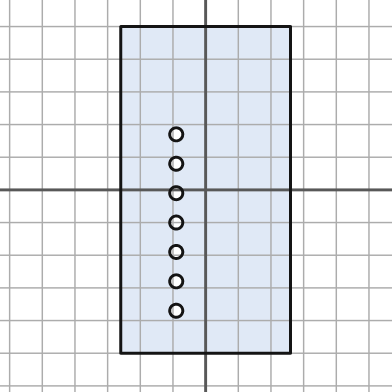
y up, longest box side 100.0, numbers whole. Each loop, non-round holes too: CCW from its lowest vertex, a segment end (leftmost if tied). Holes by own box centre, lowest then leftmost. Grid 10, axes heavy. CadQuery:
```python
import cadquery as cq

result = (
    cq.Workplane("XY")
    .moveTo(-26.0, -50.0)
    .lineTo(26.0, -50.0)
    .lineTo(26.0, 50.0)
    .lineTo(-26.0, 50.0)
    .close()
    .moveTo(-9.0, -37.0)
    .circle(2.0)
    .moveTo(-9.0, -28.0)
    .circle(2.0)
    .moveTo(-9.0, -19.0)
    .circle(2.0)
    .moveTo(-9.0, -10.0)
    .circle(2.0)
    .moveTo(-9.0, -1.0)
    .circle(2.0)
    .moveTo(-9.0, 8.0)
    .circle(2.0)
    .moveTo(-9.0, 17.0)
    .circle(2.0)
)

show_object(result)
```